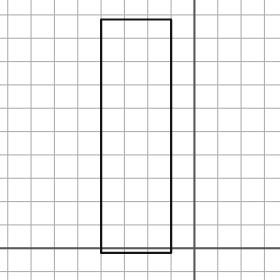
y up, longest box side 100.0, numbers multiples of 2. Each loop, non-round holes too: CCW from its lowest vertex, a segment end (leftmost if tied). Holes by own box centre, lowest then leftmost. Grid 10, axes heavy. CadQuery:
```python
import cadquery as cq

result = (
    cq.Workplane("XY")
    .moveTo(-40.0, -2.0)
    .lineTo(-10.0, -2.0)
    .lineTo(-10.0, 98.0)
    .lineTo(-40.0, 98.0)
    .close()
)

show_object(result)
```